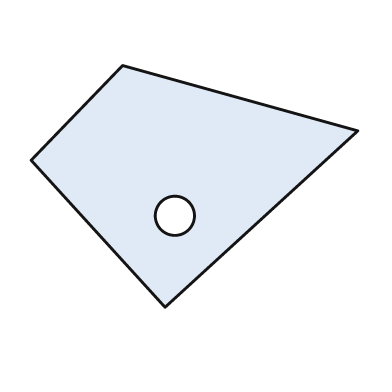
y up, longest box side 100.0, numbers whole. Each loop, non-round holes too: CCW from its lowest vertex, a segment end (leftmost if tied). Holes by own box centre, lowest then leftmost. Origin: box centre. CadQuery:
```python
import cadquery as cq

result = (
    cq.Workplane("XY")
    .moveTo(-9.0, -37.0)
    .lineTo(50.0, 17.0)
    .lineTo(-22.0, 37.0)
    .lineTo(-50.0, 8.0)
    .close()
    .moveTo(-6.0, -9.0)
    .circle(6.0)
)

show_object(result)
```